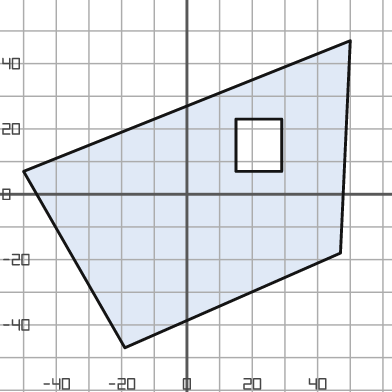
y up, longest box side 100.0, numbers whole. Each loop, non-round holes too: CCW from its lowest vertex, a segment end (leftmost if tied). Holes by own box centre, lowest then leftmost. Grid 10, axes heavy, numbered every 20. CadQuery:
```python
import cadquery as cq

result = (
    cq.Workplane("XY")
    .moveTo(-19.0, -47.0)
    .lineTo(47.0, -18.0)
    .lineTo(50.0, 47.0)
    .lineTo(-50.0, 7.0)
    .close()
    .moveTo(15.0, 7.0)
    .lineTo(29.0, 7.0)
    .lineTo(29.0, 23.0)
    .lineTo(15.0, 23.0)
    .close()
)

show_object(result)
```